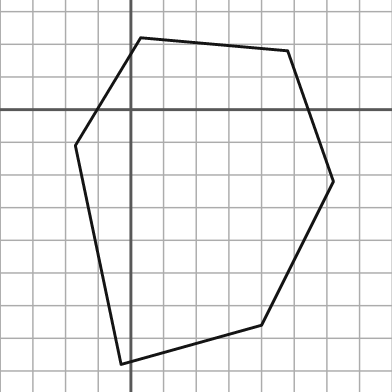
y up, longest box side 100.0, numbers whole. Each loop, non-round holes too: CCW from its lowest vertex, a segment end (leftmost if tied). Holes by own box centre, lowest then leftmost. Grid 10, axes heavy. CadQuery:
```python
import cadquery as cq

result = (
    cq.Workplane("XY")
    .moveTo(-3.0, -78.0)
    .lineTo(40.0, -66.0)
    .lineTo(62.0, -22.0)
    .lineTo(48.0, 18.0)
    .lineTo(3.0, 22.0)
    .lineTo(-17.0, -11.0)
    .close()
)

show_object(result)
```